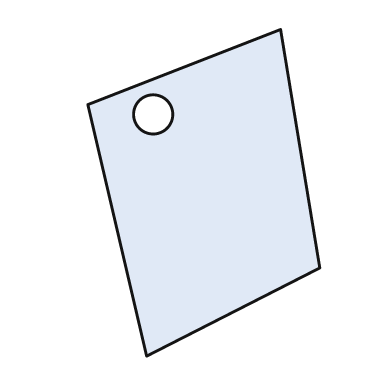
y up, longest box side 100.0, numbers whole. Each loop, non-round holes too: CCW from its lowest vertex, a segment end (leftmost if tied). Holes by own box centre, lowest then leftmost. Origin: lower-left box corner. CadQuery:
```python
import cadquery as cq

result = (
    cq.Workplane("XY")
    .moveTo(18.0, 0.0)
    .lineTo(71.0, 27.0)
    .lineTo(59.0, 100.0)
    .lineTo(0.0, 77.0)
    .close()
    .moveTo(20.0, 74.0)
    .circle(6.0)
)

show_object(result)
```